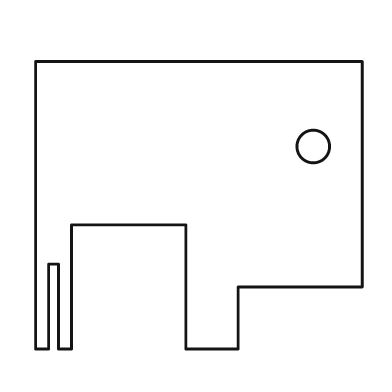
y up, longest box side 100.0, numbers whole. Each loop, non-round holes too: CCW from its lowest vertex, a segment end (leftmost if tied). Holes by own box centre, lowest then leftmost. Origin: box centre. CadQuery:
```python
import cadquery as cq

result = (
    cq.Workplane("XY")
    .moveTo(-50.0, -44.0)
    .lineTo(-46.0, -44.0)
    .lineTo(-46.0, -18.0)
    .lineTo(-43.0, -18.0)
    .lineTo(-43.0, -44.0)
    .lineTo(-39.0, -44.0)
    .lineTo(-39.0, -6.0)
    .lineTo(-4.0, -6.0)
    .lineTo(-4.0, -44.0)
    .lineTo(12.0, -44.0)
    .lineTo(12.0, -25.0)
    .lineTo(50.0, -25.0)
    .lineTo(50.0, 44.0)
    .lineTo(-50.0, 44.0)
    .close()
    .moveTo(35.0, 18.0)
    .circle(5.0)
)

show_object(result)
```